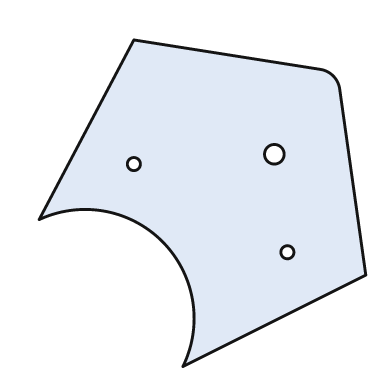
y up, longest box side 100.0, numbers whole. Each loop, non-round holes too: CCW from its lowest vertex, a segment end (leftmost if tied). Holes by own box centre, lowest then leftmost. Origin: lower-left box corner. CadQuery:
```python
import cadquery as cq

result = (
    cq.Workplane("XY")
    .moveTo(44.0, 0.0)
    .lineTo(100.0, 28.0)
    .lineTo(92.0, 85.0)
    .threePointArc((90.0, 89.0), (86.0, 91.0))
    .lineTo(29.0, 100.0)
    .lineTo(0.0, 45.0)
    .threePointArc((38.0, 38.0), (44.0, 0.0))
    .close()
    .moveTo(76.0, 35.0)
    .circle(2.0)
    .moveTo(29.0, 62.0)
    .circle(2.0)
    .moveTo(72.0, 65.0)
    .circle(3.0)
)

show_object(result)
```